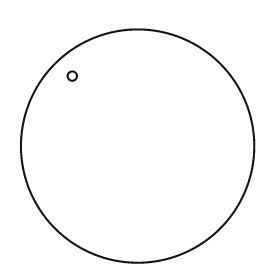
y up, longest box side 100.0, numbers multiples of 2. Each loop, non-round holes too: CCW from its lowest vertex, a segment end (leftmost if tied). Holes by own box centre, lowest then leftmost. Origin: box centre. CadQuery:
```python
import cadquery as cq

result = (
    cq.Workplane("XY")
    .moveTo(0.0, 0.0)
    .circle(50.0)
    .moveTo(-28.0, 30.0)
    .circle(2.0)
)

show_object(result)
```